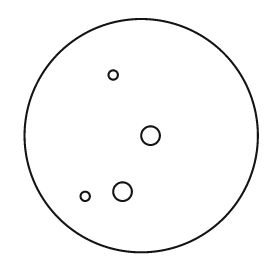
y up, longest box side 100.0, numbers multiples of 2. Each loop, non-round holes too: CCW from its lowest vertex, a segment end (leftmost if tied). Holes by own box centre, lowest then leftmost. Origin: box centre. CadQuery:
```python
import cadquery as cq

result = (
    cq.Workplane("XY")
    .moveTo(0.0, 0.0)
    .circle(50.0)
    .moveTo(-24.0, -26.0)
    .circle(2.0)
    .moveTo(-8.0, -24.0)
    .circle(4.0)
    .moveTo(4.0, 0.0)
    .circle(4.0)
    .moveTo(-12.0, 26.0)
    .circle(2.0)
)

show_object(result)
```